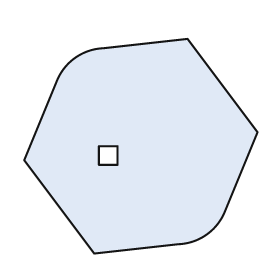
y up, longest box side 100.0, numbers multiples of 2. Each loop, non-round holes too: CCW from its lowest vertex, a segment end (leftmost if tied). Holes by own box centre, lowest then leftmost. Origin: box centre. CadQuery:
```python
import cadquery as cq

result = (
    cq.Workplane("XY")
    .moveTo(-20.0, -46.0)
    .lineTo(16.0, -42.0)
    .threePointArc((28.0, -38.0), (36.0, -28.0))
    .lineTo(50.0, 6.0)
    .lineTo(20.0, 46.0)
    .lineTo(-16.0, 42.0)
    .threePointArc((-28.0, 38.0), (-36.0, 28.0))
    .lineTo(-50.0, -6.0)
    .close()
    .moveTo(-18.0, -8.0)
    .lineTo(-10.0, -8.0)
    .lineTo(-10.0, 0.0)
    .lineTo(-18.0, 0.0)
    .close()
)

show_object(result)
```